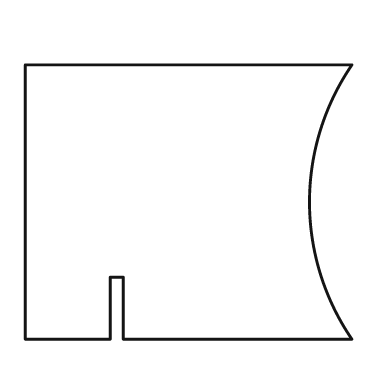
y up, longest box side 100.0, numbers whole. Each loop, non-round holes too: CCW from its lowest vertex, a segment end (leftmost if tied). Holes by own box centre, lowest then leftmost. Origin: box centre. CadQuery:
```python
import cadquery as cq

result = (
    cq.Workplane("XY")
    .moveTo(-50.0, -42.0)
    .lineTo(-24.0, -42.0)
    .lineTo(-24.0, -23.0)
    .lineTo(-20.0, -23.0)
    .lineTo(-20.0, -42.0)
    .lineTo(50.0, -42.0)
    .threePointArc((37.0, 0.0), (50.0, 42.0))
    .lineTo(-50.0, 42.0)
    .close()
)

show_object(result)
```